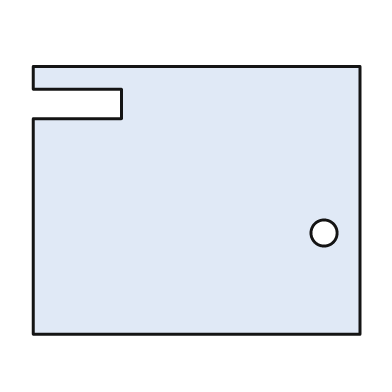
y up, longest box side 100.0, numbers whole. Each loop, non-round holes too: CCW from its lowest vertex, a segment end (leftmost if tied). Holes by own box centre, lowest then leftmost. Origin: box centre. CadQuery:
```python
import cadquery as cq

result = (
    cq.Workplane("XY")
    .moveTo(-50.0, -41.0)
    .lineTo(50.0, -41.0)
    .lineTo(50.0, 41.0)
    .lineTo(-50.0, 41.0)
    .lineTo(-50.0, 34.0)
    .lineTo(-23.0, 34.0)
    .lineTo(-23.0, 25.0)
    .lineTo(-50.0, 25.0)
    .close()
    .moveTo(39.0, -10.0)
    .circle(4.0)
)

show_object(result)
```